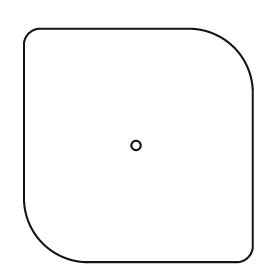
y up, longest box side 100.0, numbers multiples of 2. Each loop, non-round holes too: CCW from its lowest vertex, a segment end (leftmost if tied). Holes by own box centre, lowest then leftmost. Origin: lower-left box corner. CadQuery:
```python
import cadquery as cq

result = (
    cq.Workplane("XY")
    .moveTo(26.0, 0.0)
    .lineTo(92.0, 0.0)
    .threePointArc((96.0, 2.0), (98.0, 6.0))
    .lineTo(98.0, 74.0)
    .threePointArc((90.0, 92.0), (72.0, 100.0))
    .lineTo(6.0, 100.0)
    .threePointArc((2.0, 98.0), (0.0, 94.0))
    .lineTo(0.0, 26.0)
    .threePointArc((8.0, 8.0), (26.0, 0.0))
    .close()
    .moveTo(48.0, 50.0)
    .circle(2.0)
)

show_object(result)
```